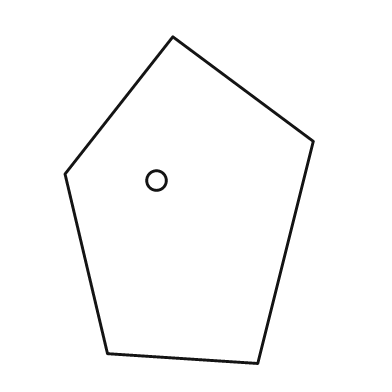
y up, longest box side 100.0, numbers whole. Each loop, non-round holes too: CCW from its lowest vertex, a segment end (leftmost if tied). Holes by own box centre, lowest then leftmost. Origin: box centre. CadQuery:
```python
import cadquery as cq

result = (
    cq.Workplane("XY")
    .moveTo(21.0, -50.0)
    .lineTo(38.0, 18.0)
    .lineTo(-5.0, 50.0)
    .lineTo(-38.0, 8.0)
    .lineTo(-25.0, -47.0)
    .close()
    .moveTo(-10.0, 6.0)
    .circle(3.0)
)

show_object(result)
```